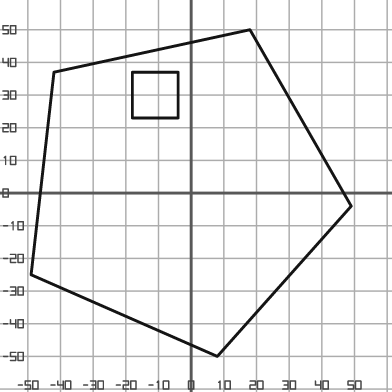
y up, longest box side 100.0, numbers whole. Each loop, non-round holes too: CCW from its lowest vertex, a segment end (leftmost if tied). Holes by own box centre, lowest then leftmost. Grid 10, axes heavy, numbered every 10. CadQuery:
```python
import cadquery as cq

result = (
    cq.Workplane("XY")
    .moveTo(8.0, -50.0)
    .lineTo(49.0, -4.0)
    .lineTo(18.0, 50.0)
    .lineTo(-42.0, 37.0)
    .lineTo(-49.0, -25.0)
    .close()
    .moveTo(-18.0, 23.0)
    .lineTo(-4.0, 23.0)
    .lineTo(-4.0, 37.0)
    .lineTo(-18.0, 37.0)
    .close()
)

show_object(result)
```